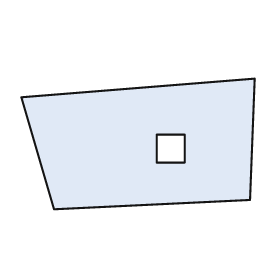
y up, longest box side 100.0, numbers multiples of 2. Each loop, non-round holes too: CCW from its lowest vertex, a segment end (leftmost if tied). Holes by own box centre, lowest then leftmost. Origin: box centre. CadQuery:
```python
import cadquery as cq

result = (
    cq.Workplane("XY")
    .moveTo(-36.0, -28.0)
    .lineTo(48.0, -24.0)
    .lineTo(50.0, 28.0)
    .lineTo(-50.0, 20.0)
    .close()
    .moveTo(8.0, -8.0)
    .lineTo(20.0, -8.0)
    .lineTo(20.0, 4.0)
    .lineTo(8.0, 4.0)
    .close()
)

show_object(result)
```